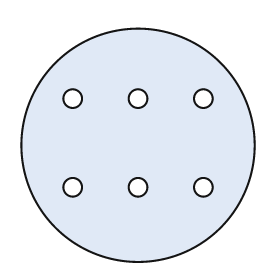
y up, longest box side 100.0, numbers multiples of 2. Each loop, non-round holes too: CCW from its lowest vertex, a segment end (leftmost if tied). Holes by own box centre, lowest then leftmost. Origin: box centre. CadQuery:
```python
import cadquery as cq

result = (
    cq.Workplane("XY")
    .moveTo(0.0, 0.0)
    .circle(50.0)
    .moveTo(-28.0, -18.0)
    .circle(4.0)
    .moveTo(0.0, -18.0)
    .circle(4.0)
    .moveTo(28.0, -18.0)
    .circle(4.0)
    .moveTo(-28.0, 20.0)
    .circle(4.0)
    .moveTo(0.0, 20.0)
    .circle(4.0)
    .moveTo(28.0, 20.0)
    .circle(4.0)
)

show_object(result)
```